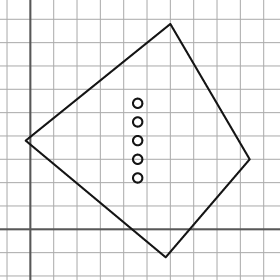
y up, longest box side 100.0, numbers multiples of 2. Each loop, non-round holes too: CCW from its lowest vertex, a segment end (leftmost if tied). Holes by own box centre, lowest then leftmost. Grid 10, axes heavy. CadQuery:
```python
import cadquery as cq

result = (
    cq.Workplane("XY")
    .moveTo(58.0, -12.0)
    .lineTo(94.0, 30.0)
    .lineTo(60.0, 88.0)
    .lineTo(-2.0, 38.0)
    .close()
    .moveTo(46.0, 22.0)
    .circle(2.0)
    .moveTo(46.0, 30.0)
    .circle(2.0)
    .moveTo(46.0, 38.0)
    .circle(2.0)
    .moveTo(46.0, 46.0)
    .circle(2.0)
    .moveTo(46.0, 54.0)
    .circle(2.0)
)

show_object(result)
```